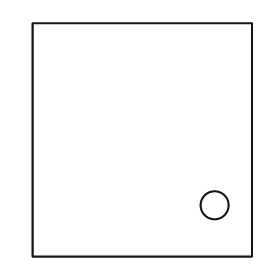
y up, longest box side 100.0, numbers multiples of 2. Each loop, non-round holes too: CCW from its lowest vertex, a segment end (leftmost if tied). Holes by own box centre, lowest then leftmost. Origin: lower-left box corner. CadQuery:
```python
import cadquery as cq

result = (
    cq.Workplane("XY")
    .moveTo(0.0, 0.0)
    .lineTo(94.0, 0.0)
    .lineTo(94.0, 100.0)
    .lineTo(0.0, 100.0)
    .close()
    .moveTo(78.0, 22.0)
    .circle(6.0)
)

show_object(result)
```